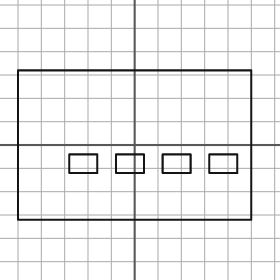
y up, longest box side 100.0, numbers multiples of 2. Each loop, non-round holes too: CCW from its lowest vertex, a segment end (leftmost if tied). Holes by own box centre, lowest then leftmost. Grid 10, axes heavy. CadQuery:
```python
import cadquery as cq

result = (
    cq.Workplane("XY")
    .moveTo(-50.0, -32.0)
    .lineTo(50.0, -32.0)
    .lineTo(50.0, 32.0)
    .lineTo(-50.0, 32.0)
    .close()
    .moveTo(-28.0, -12.0)
    .lineTo(-16.0, -12.0)
    .lineTo(-16.0, -4.0)
    .lineTo(-28.0, -4.0)
    .close()
    .moveTo(-8.0, -12.0)
    .lineTo(4.0, -12.0)
    .lineTo(4.0, -4.0)
    .lineTo(-8.0, -4.0)
    .close()
    .moveTo(12.0, -12.0)
    .lineTo(24.0, -12.0)
    .lineTo(24.0, -4.0)
    .lineTo(12.0, -4.0)
    .close()
    .moveTo(32.0, -12.0)
    .lineTo(44.0, -12.0)
    .lineTo(44.0, -4.0)
    .lineTo(32.0, -4.0)
    .close()
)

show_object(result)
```